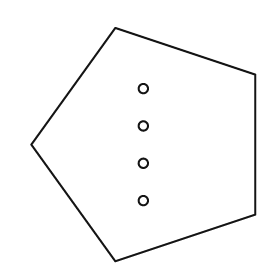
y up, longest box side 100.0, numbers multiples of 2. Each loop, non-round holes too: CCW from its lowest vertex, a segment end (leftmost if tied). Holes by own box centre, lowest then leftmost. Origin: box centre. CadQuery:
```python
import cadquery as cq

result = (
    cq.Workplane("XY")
    .moveTo(-12.0, -50.0)
    .lineTo(48.0, -30.0)
    .lineTo(48.0, 30.0)
    .lineTo(-12.0, 50.0)
    .lineTo(-48.0, 0.0)
    .close()
    .moveTo(0.0, -24.0)
    .circle(2.0)
    .moveTo(0.0, -8.0)
    .circle(2.0)
    .moveTo(0.0, 8.0)
    .circle(2.0)
    .moveTo(0.0, 24.0)
    .circle(2.0)
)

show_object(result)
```